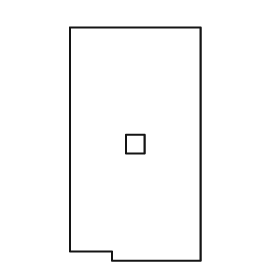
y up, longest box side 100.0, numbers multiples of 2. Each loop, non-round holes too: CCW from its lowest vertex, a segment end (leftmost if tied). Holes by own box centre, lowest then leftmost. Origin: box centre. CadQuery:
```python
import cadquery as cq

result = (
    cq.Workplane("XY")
    .moveTo(-10.0, -50.0)
    .lineTo(28.0, -50.0)
    .lineTo(28.0, 50.0)
    .lineTo(-28.0, 50.0)
    .lineTo(-28.0, -46.0)
    .lineTo(-10.0, -46.0)
    .close()
    .moveTo(-4.0, -4.0)
    .lineTo(4.0, -4.0)
    .lineTo(4.0, 4.0)
    .lineTo(-4.0, 4.0)
    .close()
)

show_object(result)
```